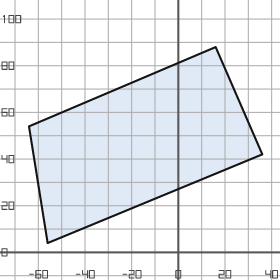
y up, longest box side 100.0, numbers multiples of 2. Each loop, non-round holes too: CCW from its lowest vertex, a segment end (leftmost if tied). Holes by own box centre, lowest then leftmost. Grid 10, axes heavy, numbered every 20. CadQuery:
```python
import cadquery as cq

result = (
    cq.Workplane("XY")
    .moveTo(-56.0, 4.0)
    .lineTo(36.0, 42.0)
    .lineTo(16.0, 88.0)
    .lineTo(-64.0, 54.0)
    .close()
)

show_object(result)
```